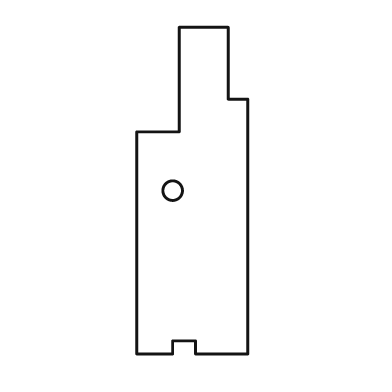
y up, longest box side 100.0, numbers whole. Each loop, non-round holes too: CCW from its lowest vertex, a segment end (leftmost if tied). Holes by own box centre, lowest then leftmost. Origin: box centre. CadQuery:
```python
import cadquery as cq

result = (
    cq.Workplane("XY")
    .moveTo(-17.0, -50.0)
    .lineTo(-6.0, -50.0)
    .lineTo(-6.0, -46.0)
    .lineTo(1.0, -46.0)
    .lineTo(1.0, -50.0)
    .lineTo(17.0, -50.0)
    .lineTo(17.0, 28.0)
    .lineTo(11.0, 28.0)
    .lineTo(11.0, 50.0)
    .lineTo(-4.0, 50.0)
    .lineTo(-4.0, 18.0)
    .lineTo(-17.0, 18.0)
    .close()
    .moveTo(-6.0, 0.0)
    .circle(3.0)
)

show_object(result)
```